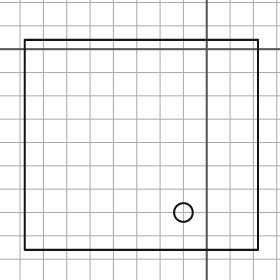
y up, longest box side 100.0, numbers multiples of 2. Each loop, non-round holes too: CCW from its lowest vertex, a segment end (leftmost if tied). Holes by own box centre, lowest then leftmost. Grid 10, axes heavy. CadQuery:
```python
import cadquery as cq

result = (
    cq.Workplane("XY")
    .moveTo(-78.0, -86.0)
    .lineTo(22.0, -86.0)
    .lineTo(22.0, 4.0)
    .lineTo(-78.0, 4.0)
    .close()
    .moveTo(-10.0, -70.0)
    .circle(4.0)
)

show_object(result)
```